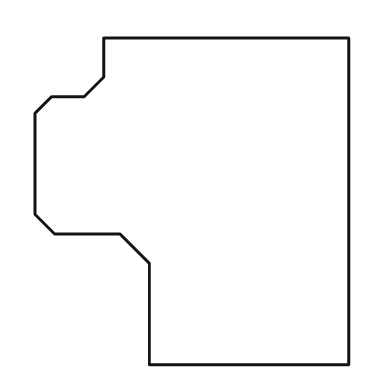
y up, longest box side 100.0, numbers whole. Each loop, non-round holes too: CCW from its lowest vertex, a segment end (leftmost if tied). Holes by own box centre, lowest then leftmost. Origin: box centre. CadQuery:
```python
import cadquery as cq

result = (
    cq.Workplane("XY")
    .moveTo(-13.0, -50.0)
    .lineTo(48.0, -50.0)
    .lineTo(48.0, 50.0)
    .lineTo(-27.0, 50.0)
    .lineTo(-27.0, 38.0)
    .lineTo(-33.0, 32.0)
    .lineTo(-43.0, 32.0)
    .lineTo(-48.0, 27.0)
    .lineTo(-48.0, -4.0)
    .lineTo(-42.0, -10.0)
    .lineTo(-22.0, -10.0)
    .lineTo(-13.0, -19.0)
    .close()
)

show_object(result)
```